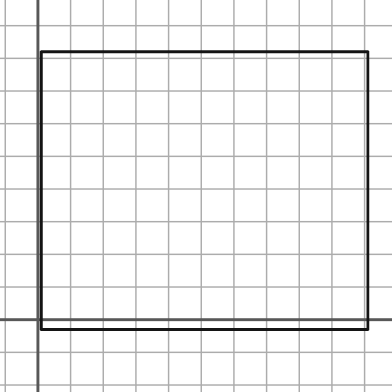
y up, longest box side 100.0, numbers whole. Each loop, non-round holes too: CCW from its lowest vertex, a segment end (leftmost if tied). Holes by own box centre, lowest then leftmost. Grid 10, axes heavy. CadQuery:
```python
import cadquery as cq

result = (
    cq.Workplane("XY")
    .moveTo(1.0, -3.0)
    .lineTo(101.0, -3.0)
    .lineTo(101.0, 82.0)
    .lineTo(1.0, 82.0)
    .close()
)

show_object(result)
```